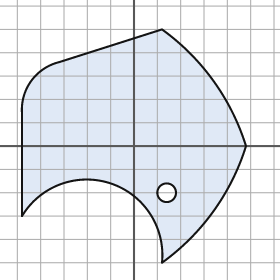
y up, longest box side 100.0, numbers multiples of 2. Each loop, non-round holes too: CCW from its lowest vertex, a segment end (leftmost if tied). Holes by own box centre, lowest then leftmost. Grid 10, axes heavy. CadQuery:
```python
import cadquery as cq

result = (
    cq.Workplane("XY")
    .moveTo(12.0, -50.0)
    .threePointArc((34.0, -28.0), (48.0, 0.0))
    .threePointArc((34.0, 28.0), (12.0, 50.0))
    .lineTo(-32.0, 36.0)
    .threePointArc((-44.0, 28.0), (-48.0, 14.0))
    .lineTo(-48.0, -30.0)
    .threePointArc((-10.0, -16.0), (12.0, -50.0))
    .close()
    .moveTo(14.0, -20.0)
    .circle(4.0)
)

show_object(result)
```